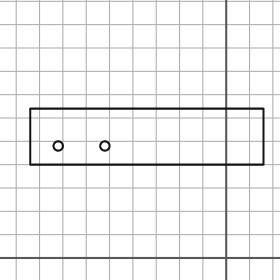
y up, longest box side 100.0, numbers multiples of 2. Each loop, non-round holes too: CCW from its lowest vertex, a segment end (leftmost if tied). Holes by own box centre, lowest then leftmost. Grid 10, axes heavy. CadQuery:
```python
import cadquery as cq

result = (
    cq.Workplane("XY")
    .moveTo(-84.0, 40.0)
    .lineTo(16.0, 40.0)
    .lineTo(16.0, 64.0)
    .lineTo(-84.0, 64.0)
    .close()
    .moveTo(-72.0, 48.0)
    .circle(2.0)
    .moveTo(-52.0, 48.0)
    .circle(2.0)
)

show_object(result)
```